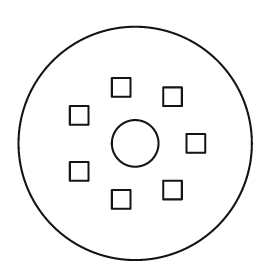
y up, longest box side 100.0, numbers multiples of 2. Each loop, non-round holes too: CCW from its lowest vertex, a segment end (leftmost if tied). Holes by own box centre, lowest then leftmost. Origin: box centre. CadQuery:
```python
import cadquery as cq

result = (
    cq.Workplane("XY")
    .moveTo(0.0, 0.0)
    .circle(50.0)
    .moveTo(-10.0, -28.0)
    .lineTo(-2.0, -28.0)
    .lineTo(-2.0, -20.0)
    .lineTo(-10.0, -20.0)
    .close()
    .moveTo(12.0, -24.0)
    .lineTo(20.0, -24.0)
    .lineTo(20.0, -16.0)
    .lineTo(12.0, -16.0)
    .close()
    .moveTo(-28.0, -16.0)
    .lineTo(-20.0, -16.0)
    .lineTo(-20.0, -8.0)
    .lineTo(-28.0, -8.0)
    .close()
    .moveTo(0.0, 0.0)
    .circle(10.0)
    .moveTo(22.0, -4.0)
    .lineTo(30.0, -4.0)
    .lineTo(30.0, 4.0)
    .lineTo(22.0, 4.0)
    .close()
    .moveTo(-28.0, 8.0)
    .lineTo(-20.0, 8.0)
    .lineTo(-20.0, 16.0)
    .lineTo(-28.0, 16.0)
    .close()
    .moveTo(12.0, 16.0)
    .lineTo(20.0, 16.0)
    .lineTo(20.0, 24.0)
    .lineTo(12.0, 24.0)
    .close()
    .moveTo(-10.0, 20.0)
    .lineTo(-2.0, 20.0)
    .lineTo(-2.0, 28.0)
    .lineTo(-10.0, 28.0)
    .close()
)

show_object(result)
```